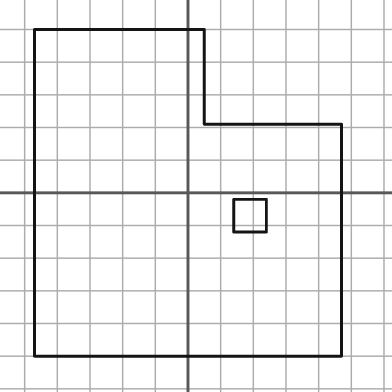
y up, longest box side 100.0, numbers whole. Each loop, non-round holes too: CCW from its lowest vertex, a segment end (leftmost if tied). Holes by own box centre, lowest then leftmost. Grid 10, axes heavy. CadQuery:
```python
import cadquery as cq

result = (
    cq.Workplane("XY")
    .moveTo(-47.0, -50.0)
    .lineTo(47.0, -50.0)
    .lineTo(47.0, 21.0)
    .lineTo(5.0, 21.0)
    .lineTo(5.0, 50.0)
    .lineTo(-47.0, 50.0)
    .close()
    .moveTo(14.0, -12.0)
    .lineTo(24.0, -12.0)
    .lineTo(24.0, -2.0)
    .lineTo(14.0, -2.0)
    .close()
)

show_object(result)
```